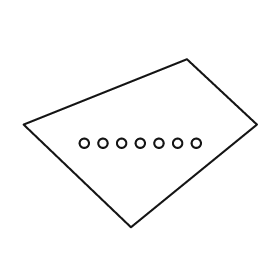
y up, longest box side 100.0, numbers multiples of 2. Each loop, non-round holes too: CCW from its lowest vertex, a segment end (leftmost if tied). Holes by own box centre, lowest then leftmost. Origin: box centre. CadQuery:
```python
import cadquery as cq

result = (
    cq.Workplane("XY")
    .moveTo(-4.0, -36.0)
    .lineTo(50.0, 8.0)
    .lineTo(20.0, 36.0)
    .lineTo(-50.0, 8.0)
    .close()
    .moveTo(-24.0, 0.0)
    .circle(2.0)
    .moveTo(-16.0, 0.0)
    .circle(2.0)
    .moveTo(-8.0, 0.0)
    .circle(2.0)
    .moveTo(0.0, 0.0)
    .circle(2.0)
    .moveTo(8.0, 0.0)
    .circle(2.0)
    .moveTo(16.0, 0.0)
    .circle(2.0)
    .moveTo(24.0, 0.0)
    .circle(2.0)
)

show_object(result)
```